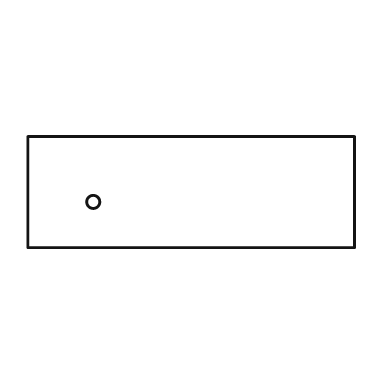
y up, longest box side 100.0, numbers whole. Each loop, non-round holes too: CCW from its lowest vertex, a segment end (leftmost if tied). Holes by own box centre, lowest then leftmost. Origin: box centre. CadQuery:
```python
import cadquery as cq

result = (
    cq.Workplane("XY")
    .moveTo(-50.0, -17.0)
    .lineTo(50.0, -17.0)
    .lineTo(50.0, 17.0)
    .lineTo(-50.0, 17.0)
    .close()
    .moveTo(-30.0, -3.0)
    .circle(2.0)
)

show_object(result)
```